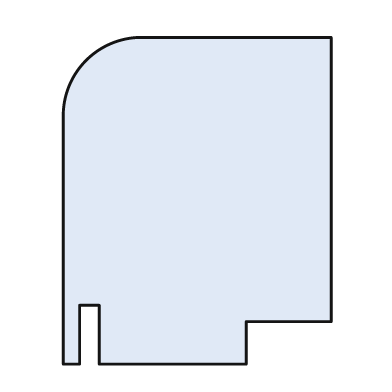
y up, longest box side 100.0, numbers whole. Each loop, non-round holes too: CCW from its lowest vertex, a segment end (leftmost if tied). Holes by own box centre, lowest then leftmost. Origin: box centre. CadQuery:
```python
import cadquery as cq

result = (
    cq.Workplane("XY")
    .moveTo(-41.0, -50.0)
    .lineTo(-36.0, -50.0)
    .lineTo(-36.0, -32.0)
    .lineTo(-30.0, -32.0)
    .lineTo(-30.0, -50.0)
    .lineTo(15.0, -50.0)
    .lineTo(15.0, -37.0)
    .lineTo(41.0, -37.0)
    .lineTo(41.0, 50.0)
    .lineTo(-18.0, 50.0)
    .threePointArc((-34.0, 43.0), (-41.0, 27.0))
    .close()
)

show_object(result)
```